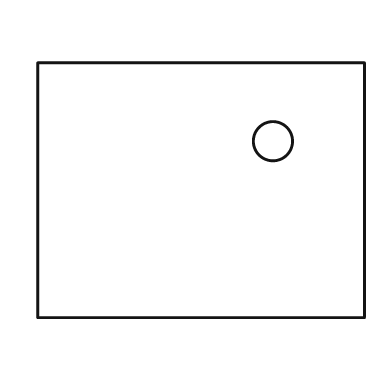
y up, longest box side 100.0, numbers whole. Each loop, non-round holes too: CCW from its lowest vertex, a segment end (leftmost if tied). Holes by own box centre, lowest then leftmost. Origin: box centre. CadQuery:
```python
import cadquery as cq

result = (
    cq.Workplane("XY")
    .moveTo(-50.0, -39.0)
    .lineTo(50.0, -39.0)
    .lineTo(50.0, 39.0)
    .lineTo(-50.0, 39.0)
    .close()
    .moveTo(22.0, 15.0)
    .circle(6.0)
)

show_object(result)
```